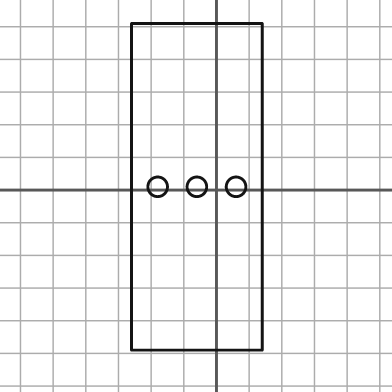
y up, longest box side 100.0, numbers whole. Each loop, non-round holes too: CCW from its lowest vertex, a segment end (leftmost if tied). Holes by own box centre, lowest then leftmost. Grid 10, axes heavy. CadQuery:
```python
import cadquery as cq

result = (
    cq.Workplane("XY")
    .moveTo(-26.0, -49.0)
    .lineTo(14.0, -49.0)
    .lineTo(14.0, 51.0)
    .lineTo(-26.0, 51.0)
    .close()
    .moveTo(-18.0, 1.0)
    .circle(3.0)
    .moveTo(-6.0, 1.0)
    .circle(3.0)
    .moveTo(6.0, 1.0)
    .circle(3.0)
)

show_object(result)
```